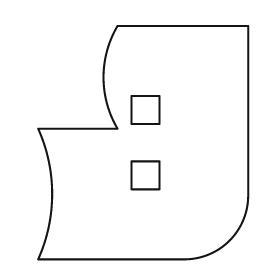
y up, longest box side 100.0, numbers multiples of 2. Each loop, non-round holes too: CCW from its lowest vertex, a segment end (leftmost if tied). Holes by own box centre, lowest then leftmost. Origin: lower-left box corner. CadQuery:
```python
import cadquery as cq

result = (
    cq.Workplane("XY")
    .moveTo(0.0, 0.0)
    .lineTo(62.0, 0.0)
    .threePointArc((82.0, 8.0), (90.0, 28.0))
    .lineTo(90.0, 100.0)
    .lineTo(34.0, 100.0)
    .threePointArc((28.0, 78.0), (34.0, 56.0))
    .lineTo(0.0, 56.0)
    .threePointArc((6.0, 28.0), (0.0, 0.0))
    .close()
    .moveTo(40.0, 30.0)
    .lineTo(52.0, 30.0)
    .lineTo(52.0, 42.0)
    .lineTo(40.0, 42.0)
    .close()
    .moveTo(40.0, 58.0)
    .lineTo(52.0, 58.0)
    .lineTo(52.0, 70.0)
    .lineTo(40.0, 70.0)
    .close()
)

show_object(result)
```